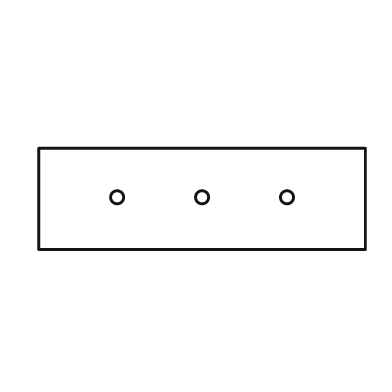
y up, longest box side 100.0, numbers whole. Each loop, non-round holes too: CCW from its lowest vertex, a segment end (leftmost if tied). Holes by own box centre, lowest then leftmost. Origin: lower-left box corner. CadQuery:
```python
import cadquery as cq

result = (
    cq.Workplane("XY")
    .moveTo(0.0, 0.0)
    .lineTo(100.0, 0.0)
    .lineTo(100.0, 31.0)
    .lineTo(0.0, 31.0)
    .close()
    .moveTo(24.0, 16.0)
    .circle(2.0)
    .moveTo(50.0, 16.0)
    .circle(2.0)
    .moveTo(76.0, 16.0)
    .circle(2.0)
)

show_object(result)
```